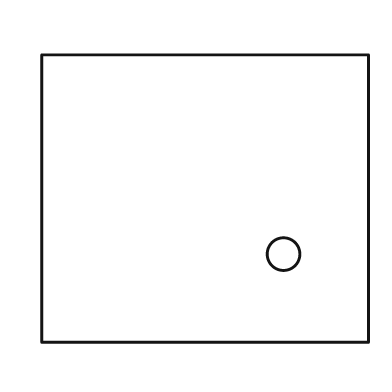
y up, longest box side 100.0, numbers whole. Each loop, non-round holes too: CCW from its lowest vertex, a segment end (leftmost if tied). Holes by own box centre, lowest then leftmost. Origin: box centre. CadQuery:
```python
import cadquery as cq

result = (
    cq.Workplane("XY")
    .moveTo(-50.0, -44.0)
    .lineTo(50.0, -44.0)
    .lineTo(50.0, 44.0)
    .lineTo(-50.0, 44.0)
    .close()
    .moveTo(24.0, -17.0)
    .circle(5.0)
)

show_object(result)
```